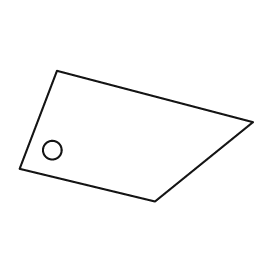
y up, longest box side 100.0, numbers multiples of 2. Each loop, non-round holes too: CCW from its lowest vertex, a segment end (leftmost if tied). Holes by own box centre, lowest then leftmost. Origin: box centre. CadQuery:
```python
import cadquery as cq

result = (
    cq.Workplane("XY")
    .moveTo(8.0, -28.0)
    .lineTo(50.0, 6.0)
    .lineTo(-34.0, 28.0)
    .lineTo(-50.0, -14.0)
    .close()
    .moveTo(-36.0, -6.0)
    .circle(4.0)
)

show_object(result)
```